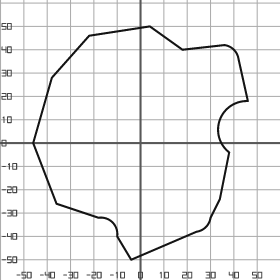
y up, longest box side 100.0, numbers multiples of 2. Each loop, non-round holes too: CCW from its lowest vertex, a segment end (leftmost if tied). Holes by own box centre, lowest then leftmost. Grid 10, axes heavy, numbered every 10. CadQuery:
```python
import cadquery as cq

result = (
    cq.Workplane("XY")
    .moveTo(-4.0, -50.0)
    .lineTo(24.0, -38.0)
    .threePointArc((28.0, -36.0), (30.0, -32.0))
    .lineTo(34.0, -24.0)
    .lineTo(38.0, -4.0)
    .threePointArc((34.0, 10.0), (46.0, 18.0))
    .lineTo(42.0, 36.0)
    .threePointArc((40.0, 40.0), (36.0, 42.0))
    .lineTo(18.0, 40.0)
    .lineTo(4.0, 50.0)
    .lineTo(-22.0, 46.0)
    .lineTo(-38.0, 28.0)
    .lineTo(-46.0, 0.0)
    .lineTo(-36.0, -26.0)
    .lineTo(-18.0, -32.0)
    .threePointArc((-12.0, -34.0), (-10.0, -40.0))
    .close()
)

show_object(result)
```